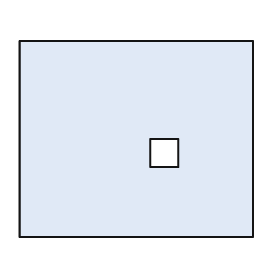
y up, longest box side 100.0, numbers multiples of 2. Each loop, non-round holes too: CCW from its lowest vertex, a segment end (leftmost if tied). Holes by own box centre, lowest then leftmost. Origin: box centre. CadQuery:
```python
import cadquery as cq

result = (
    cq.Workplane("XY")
    .moveTo(-50.0, -42.0)
    .lineTo(50.0, -42.0)
    .lineTo(50.0, 42.0)
    .lineTo(-50.0, 42.0)
    .close()
    .moveTo(6.0, -12.0)
    .lineTo(18.0, -12.0)
    .lineTo(18.0, 0.0)
    .lineTo(6.0, 0.0)
    .close()
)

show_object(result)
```